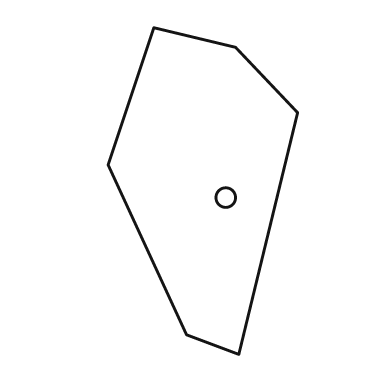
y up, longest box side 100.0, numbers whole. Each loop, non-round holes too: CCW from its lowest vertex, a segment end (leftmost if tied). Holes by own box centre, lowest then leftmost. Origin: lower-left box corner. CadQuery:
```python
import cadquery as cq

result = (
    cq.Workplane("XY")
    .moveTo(40.0, 0.0)
    .lineTo(58.0, 74.0)
    .lineTo(39.0, 94.0)
    .lineTo(14.0, 100.0)
    .lineTo(0.0, 58.0)
    .lineTo(24.0, 6.0)
    .close()
    .moveTo(36.0, 48.0)
    .circle(3.0)
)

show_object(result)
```